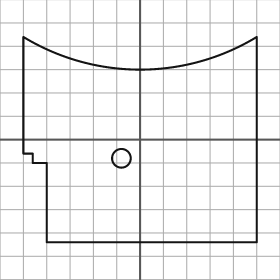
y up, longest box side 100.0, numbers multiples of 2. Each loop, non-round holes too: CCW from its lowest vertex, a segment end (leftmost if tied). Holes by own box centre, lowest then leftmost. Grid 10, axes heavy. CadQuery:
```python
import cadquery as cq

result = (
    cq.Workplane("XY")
    .moveTo(-40.0, -44.0)
    .lineTo(50.0, -44.0)
    .lineTo(50.0, 44.0)
    .threePointArc((0.0, 30.0), (-50.0, 44.0))
    .lineTo(-50.0, -6.0)
    .lineTo(-46.0, -6.0)
    .lineTo(-46.0, -10.0)
    .lineTo(-40.0, -10.0)
    .close()
    .moveTo(-8.0, -8.0)
    .circle(4.0)
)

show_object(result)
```